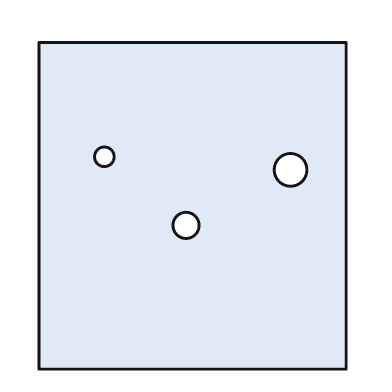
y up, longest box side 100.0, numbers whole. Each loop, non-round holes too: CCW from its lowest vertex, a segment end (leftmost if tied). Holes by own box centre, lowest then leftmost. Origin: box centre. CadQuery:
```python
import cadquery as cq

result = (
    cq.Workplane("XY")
    .moveTo(-47.0, -50.0)
    .lineTo(47.0, -50.0)
    .lineTo(47.0, 50.0)
    .lineTo(-47.0, 50.0)
    .close()
    .moveTo(-2.0, -6.0)
    .circle(4.0)
    .moveTo(30.0, 11.0)
    .circle(5.0)
    .moveTo(-27.0, 15.0)
    .circle(3.0)
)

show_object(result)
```